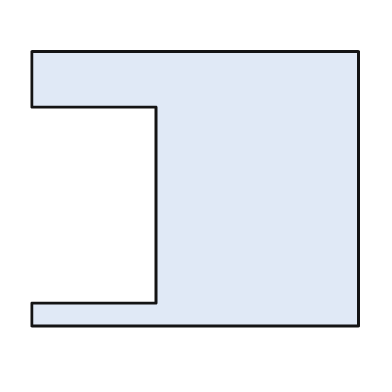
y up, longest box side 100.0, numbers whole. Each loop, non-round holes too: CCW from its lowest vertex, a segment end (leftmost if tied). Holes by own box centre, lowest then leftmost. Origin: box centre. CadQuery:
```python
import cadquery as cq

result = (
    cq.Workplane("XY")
    .moveTo(-50.0, -42.0)
    .lineTo(50.0, -42.0)
    .lineTo(50.0, 42.0)
    .lineTo(-50.0, 42.0)
    .lineTo(-50.0, 25.0)
    .lineTo(-12.0, 25.0)
    .lineTo(-12.0, -35.0)
    .lineTo(-50.0, -35.0)
    .close()
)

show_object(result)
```